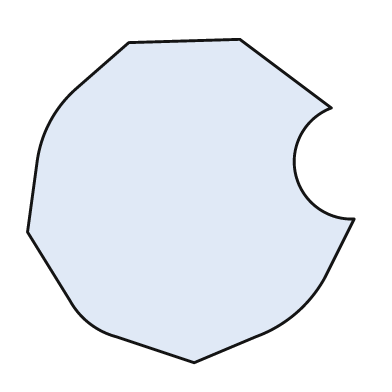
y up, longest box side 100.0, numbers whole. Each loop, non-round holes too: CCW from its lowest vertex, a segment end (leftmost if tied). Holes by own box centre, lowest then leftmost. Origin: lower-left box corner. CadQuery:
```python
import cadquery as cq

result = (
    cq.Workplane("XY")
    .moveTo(51.0, 0.0)
    .lineTo(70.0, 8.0)
    .threePointArc((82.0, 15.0), (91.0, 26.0))
    .lineTo(100.0, 44.0)
    .threePointArc((82.0, 58.0), (93.0, 78.0))
    .lineTo(65.0, 99.0)
    .lineTo(31.0, 98.0)
    .lineTo(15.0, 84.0)
    .threePointArc((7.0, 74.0), (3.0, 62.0))
    .lineTo(0.0, 40.0)
    .lineTo(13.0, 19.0)
    .threePointArc((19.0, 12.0), (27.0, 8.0))
    .close()
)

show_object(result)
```